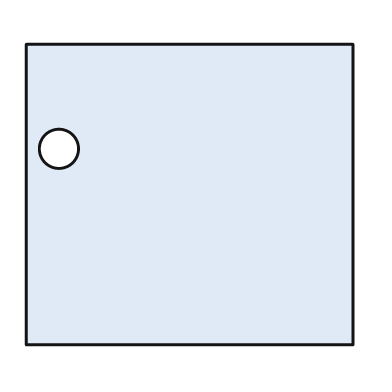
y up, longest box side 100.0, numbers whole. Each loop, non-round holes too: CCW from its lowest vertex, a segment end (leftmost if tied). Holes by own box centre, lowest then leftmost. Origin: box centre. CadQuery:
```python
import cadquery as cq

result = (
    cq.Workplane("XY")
    .moveTo(-50.0, -46.0)
    .lineTo(50.0, -46.0)
    .lineTo(50.0, 46.0)
    .lineTo(-50.0, 46.0)
    .close()
    .moveTo(-40.0, 14.0)
    .circle(6.0)
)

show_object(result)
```